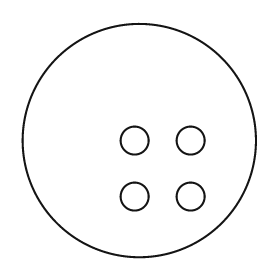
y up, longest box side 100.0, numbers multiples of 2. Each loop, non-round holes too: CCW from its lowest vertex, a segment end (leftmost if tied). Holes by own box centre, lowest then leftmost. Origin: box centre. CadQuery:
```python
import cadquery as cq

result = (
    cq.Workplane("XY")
    .moveTo(0.0, 0.0)
    .circle(50.0)
    .moveTo(-2.0, -24.0)
    .circle(6.0)
    .moveTo(22.0, -24.0)
    .circle(6.0)
    .moveTo(-2.0, 0.0)
    .circle(6.0)
    .moveTo(22.0, 0.0)
    .circle(6.0)
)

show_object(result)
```